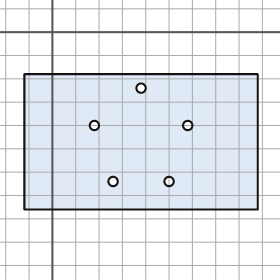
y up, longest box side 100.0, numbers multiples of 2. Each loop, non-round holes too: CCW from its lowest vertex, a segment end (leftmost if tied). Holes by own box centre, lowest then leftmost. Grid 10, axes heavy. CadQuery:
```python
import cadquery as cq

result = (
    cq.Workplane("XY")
    .moveTo(-12.0, -76.0)
    .lineTo(88.0, -76.0)
    .lineTo(88.0, -18.0)
    .lineTo(-12.0, -18.0)
    .close()
    .moveTo(26.0, -64.0)
    .circle(2.0)
    .moveTo(50.0, -64.0)
    .circle(2.0)
    .moveTo(18.0, -40.0)
    .circle(2.0)
    .moveTo(58.0, -40.0)
    .circle(2.0)
    .moveTo(38.0, -24.0)
    .circle(2.0)
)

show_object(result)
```